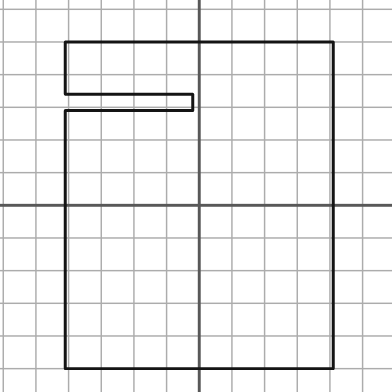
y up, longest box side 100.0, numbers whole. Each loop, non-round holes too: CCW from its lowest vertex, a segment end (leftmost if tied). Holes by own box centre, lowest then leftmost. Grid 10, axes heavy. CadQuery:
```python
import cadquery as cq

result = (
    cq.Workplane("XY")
    .moveTo(-41.0, -50.0)
    .lineTo(41.0, -50.0)
    .lineTo(41.0, 50.0)
    .lineTo(-41.0, 50.0)
    .lineTo(-41.0, 34.0)
    .lineTo(-2.0, 34.0)
    .lineTo(-2.0, 29.0)
    .lineTo(-41.0, 29.0)
    .close()
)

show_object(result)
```